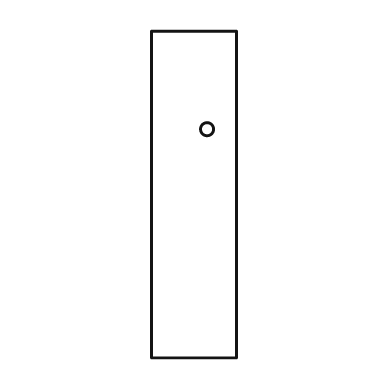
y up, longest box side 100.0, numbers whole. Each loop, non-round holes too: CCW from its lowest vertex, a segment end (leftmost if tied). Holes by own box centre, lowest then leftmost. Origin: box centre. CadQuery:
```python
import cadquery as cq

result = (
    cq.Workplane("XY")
    .moveTo(-13.0, -50.0)
    .lineTo(13.0, -50.0)
    .lineTo(13.0, 50.0)
    .lineTo(-13.0, 50.0)
    .close()
    .moveTo(4.0, 20.0)
    .circle(2.0)
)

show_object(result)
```